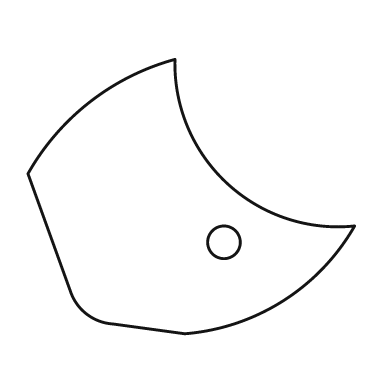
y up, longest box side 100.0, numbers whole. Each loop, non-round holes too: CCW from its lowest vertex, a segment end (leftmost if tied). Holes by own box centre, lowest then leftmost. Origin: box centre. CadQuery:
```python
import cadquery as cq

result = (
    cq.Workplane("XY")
    .moveTo(-2.0, -42.0)
    .threePointArc((28.0, -32.0), (50.0, -9.0))
    .threePointArc((11.0, 4.0), (-5.0, 42.0))
    .threePointArc((-31.0, 29.0), (-50.0, 7.0))
    .lineTo(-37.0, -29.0)
    .threePointArc((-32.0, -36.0), (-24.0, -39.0))
    .close()
    .moveTo(10.0, -14.0)
    .circle(5.0)
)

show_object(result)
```